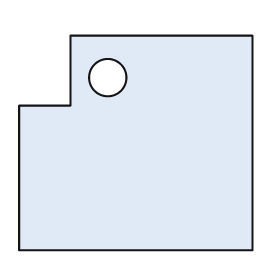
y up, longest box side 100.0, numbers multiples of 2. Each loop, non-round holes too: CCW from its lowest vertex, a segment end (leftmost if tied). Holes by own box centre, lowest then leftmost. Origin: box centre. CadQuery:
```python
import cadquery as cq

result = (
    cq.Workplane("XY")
    .moveTo(-50.0, -46.0)
    .lineTo(50.0, -46.0)
    .lineTo(50.0, 46.0)
    .lineTo(-28.0, 46.0)
    .lineTo(-28.0, 16.0)
    .lineTo(-50.0, 16.0)
    .close()
    .moveTo(-12.0, 28.0)
    .circle(8.0)
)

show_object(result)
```